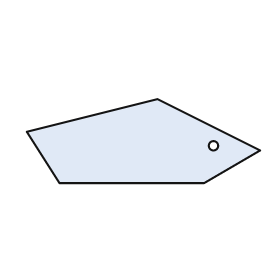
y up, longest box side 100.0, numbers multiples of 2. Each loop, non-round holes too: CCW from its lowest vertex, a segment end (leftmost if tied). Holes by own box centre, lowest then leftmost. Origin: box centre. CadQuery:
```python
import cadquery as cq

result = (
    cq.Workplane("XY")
    .moveTo(-36.0, -18.0)
    .lineTo(26.0, -18.0)
    .lineTo(50.0, -4.0)
    .lineTo(6.0, 18.0)
    .lineTo(-50.0, 4.0)
    .close()
    .moveTo(30.0, -2.0)
    .circle(2.0)
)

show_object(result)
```